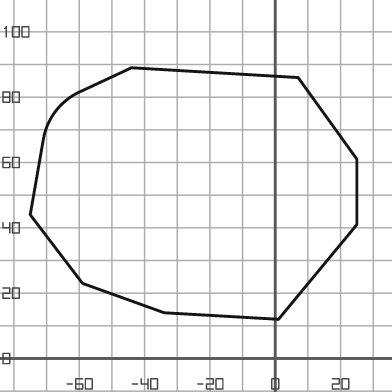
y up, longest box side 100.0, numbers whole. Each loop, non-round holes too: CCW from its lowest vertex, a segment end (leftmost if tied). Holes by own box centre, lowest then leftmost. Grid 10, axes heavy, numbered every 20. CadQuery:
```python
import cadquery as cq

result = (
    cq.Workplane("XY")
    .moveTo(1.0, 12.0)
    .lineTo(25.0, 41.0)
    .lineTo(25.0, 61.0)
    .lineTo(7.0, 86.0)
    .lineTo(-44.0, 89.0)
    .lineTo(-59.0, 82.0)
    .threePointArc((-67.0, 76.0), (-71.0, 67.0))
    .lineTo(-75.0, 44.0)
    .lineTo(-59.0, 23.0)
    .lineTo(-34.0, 14.0)
    .close()
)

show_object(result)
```